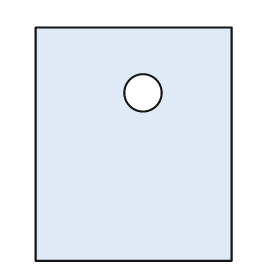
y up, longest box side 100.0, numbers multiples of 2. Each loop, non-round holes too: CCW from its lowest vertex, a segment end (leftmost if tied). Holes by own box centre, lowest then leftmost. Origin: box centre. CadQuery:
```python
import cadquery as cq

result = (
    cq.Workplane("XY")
    .moveTo(-42.0, -50.0)
    .lineTo(42.0, -50.0)
    .lineTo(42.0, 50.0)
    .lineTo(-42.0, 50.0)
    .close()
    .moveTo(4.0, 22.0)
    .circle(8.0)
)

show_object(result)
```